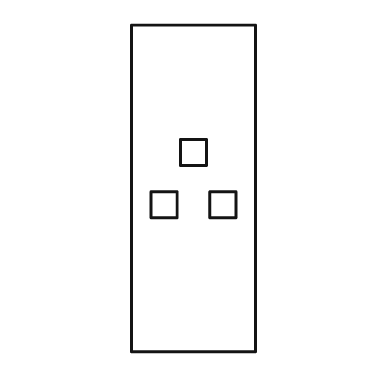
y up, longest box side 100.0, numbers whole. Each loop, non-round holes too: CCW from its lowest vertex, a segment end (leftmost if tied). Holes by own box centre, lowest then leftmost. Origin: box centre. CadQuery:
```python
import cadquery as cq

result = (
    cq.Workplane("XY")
    .moveTo(-19.0, -50.0)
    .lineTo(19.0, -50.0)
    .lineTo(19.0, 50.0)
    .lineTo(-19.0, 50.0)
    .close()
    .moveTo(-13.0, -9.0)
    .lineTo(-5.0, -9.0)
    .lineTo(-5.0, -1.0)
    .lineTo(-13.0, -1.0)
    .close()
    .moveTo(5.0, -9.0)
    .lineTo(13.0, -9.0)
    .lineTo(13.0, -1.0)
    .lineTo(5.0, -1.0)
    .close()
    .moveTo(-4.0, 7.0)
    .lineTo(4.0, 7.0)
    .lineTo(4.0, 15.0)
    .lineTo(-4.0, 15.0)
    .close()
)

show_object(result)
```